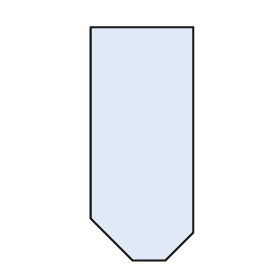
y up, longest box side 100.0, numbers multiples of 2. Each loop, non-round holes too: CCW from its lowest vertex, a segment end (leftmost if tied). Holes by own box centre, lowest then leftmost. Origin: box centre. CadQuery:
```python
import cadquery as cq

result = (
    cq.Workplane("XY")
    .moveTo(-4.0, -50.0)
    .lineTo(10.0, -50.0)
    .lineTo(22.0, -38.0)
    .lineTo(22.0, 50.0)
    .lineTo(-22.0, 50.0)
    .lineTo(-22.0, -32.0)
    .close()
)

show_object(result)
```